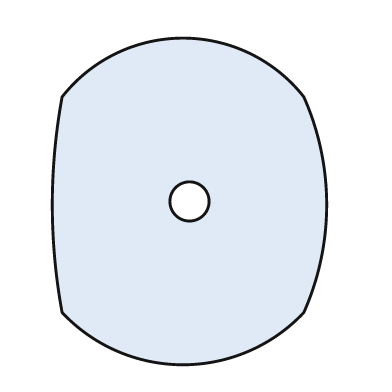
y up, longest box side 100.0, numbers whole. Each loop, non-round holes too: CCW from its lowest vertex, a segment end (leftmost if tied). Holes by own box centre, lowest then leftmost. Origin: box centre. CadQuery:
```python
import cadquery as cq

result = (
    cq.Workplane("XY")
    .moveTo(-39.0, -34.0)
    .threePointArc((-2.0, -50.0), (35.0, -34.0))
    .threePointArc((42.0, -1.0), (35.0, 32.0))
    .threePointArc((-2.0, 50.0), (-39.0, 32.0))
    .threePointArc((-42.0, -1.0), (-39.0, -34.0))
    .close()
    .moveTo(0.0, 0.0)
    .circle(6.0)
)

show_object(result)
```